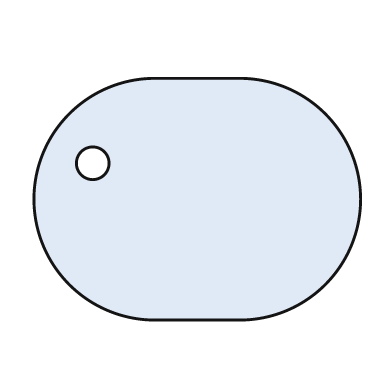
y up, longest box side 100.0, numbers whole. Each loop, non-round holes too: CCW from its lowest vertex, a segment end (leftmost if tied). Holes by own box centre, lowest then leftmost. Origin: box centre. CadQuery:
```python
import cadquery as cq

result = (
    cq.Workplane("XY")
    .moveTo(-13.0, -37.0)
    .lineTo(13.0, -37.0)
    .threePointArc((50.0, 0.0), (13.0, 37.0))
    .lineTo(-13.0, 37.0)
    .threePointArc((-50.0, 0.0), (-13.0, -37.0))
    .close()
    .moveTo(-32.0, 11.0)
    .circle(5.0)
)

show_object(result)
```